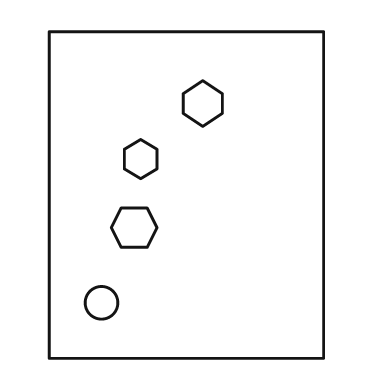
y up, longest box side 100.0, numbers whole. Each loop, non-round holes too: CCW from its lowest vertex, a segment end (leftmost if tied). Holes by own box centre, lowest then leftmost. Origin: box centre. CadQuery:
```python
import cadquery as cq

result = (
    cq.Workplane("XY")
    .moveTo(-42.0, -50.0)
    .lineTo(42.0, -50.0)
    .lineTo(42.0, 50.0)
    .lineTo(-42.0, 50.0)
    .close()
    .moveTo(-26.0, -33.0)
    .circle(5.0)
    .moveTo(-20.0, -16.0)
    .lineTo(-12.0, -16.0)
    .lineTo(-9.0, -10.0)
    .lineTo(-12.0, -4.0)
    .lineTo(-20.0, -4.0)
    .lineTo(-23.0, -10.0)
    .close()
    .moveTo(-14.0, 5.0)
    .lineTo(-9.0, 8.0)
    .lineTo(-9.0, 14.0)
    .lineTo(-14.0, 17.0)
    .lineTo(-19.0, 14.0)
    .lineTo(-19.0, 8.0)
    .close()
    .moveTo(5.0, 21.0)
    .lineTo(11.0, 25.0)
    .lineTo(11.0, 31.0)
    .lineTo(5.0, 35.0)
    .lineTo(-1.0, 31.0)
    .lineTo(-1.0, 25.0)
    .close()
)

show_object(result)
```